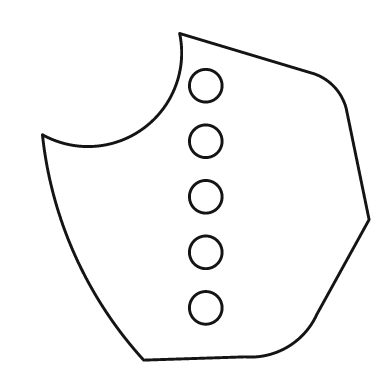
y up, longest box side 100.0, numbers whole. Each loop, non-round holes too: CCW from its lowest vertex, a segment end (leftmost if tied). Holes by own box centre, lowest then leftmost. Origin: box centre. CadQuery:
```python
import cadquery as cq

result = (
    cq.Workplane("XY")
    .moveTo(-19.0, -50.0)
    .lineTo(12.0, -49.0)
    .threePointArc((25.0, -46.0), (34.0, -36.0))
    .lineTo(50.0, -7.0)
    .lineTo(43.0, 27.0)
    .threePointArc((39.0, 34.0), (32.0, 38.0))
    .lineTo(-8.0, 50.0)
    .threePointArc((-19.0, 21.0), (-50.0, 19.0))
    .threePointArc((-40.0, -18.0), (-19.0, -50.0))
    .close()
    .moveTo(0.0, -34.0)
    .circle(5.0)
    .moveTo(0.0, -17.0)
    .circle(5.0)
    .moveTo(0.0, 0.0)
    .circle(5.0)
    .moveTo(0.0, 17.0)
    .circle(5.0)
    .moveTo(0.0, 34.0)
    .circle(5.0)
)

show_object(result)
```